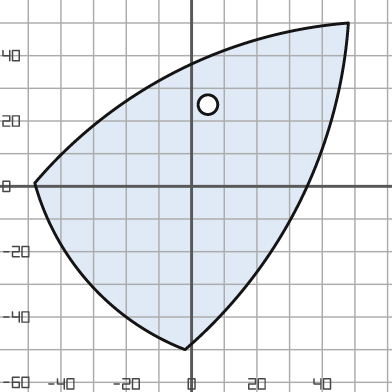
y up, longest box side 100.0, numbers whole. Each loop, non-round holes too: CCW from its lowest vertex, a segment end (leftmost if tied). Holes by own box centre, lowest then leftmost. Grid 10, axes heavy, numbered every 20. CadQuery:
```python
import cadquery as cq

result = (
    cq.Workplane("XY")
    .moveTo(-2.0, -50.0)
    .threePointArc((33.0, -5.0), (48.0, 50.0))
    .threePointArc((-5.0, 35.0), (-48.0, 1.0))
    .threePointArc((-31.0, -30.0), (-2.0, -50.0))
    .close()
    .moveTo(5.0, 25.0)
    .circle(3.0)
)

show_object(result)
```